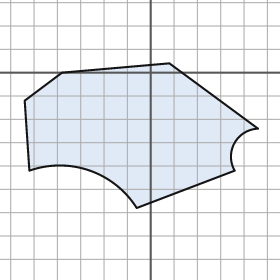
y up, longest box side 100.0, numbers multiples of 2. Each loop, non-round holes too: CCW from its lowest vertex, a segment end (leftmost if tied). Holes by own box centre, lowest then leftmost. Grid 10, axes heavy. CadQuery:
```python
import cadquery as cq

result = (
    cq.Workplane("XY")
    .moveTo(-6.0, -58.0)
    .lineTo(36.0, -42.0)
    .threePointArc((36.0, -30.0), (46.0, -24.0))
    .lineTo(8.0, 4.0)
    .lineTo(-38.0, 0.0)
    .lineTo(-54.0, -12.0)
    .lineTo(-52.0, -42.0)
    .threePointArc((-26.0, -42.0), (-6.0, -58.0))
    .close()
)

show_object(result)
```